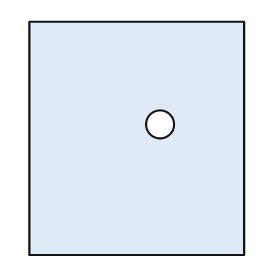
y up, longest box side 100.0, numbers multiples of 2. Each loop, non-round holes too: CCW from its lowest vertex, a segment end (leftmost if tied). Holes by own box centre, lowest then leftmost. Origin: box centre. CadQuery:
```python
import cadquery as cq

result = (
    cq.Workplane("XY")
    .moveTo(-46.0, -50.0)
    .lineTo(46.0, -50.0)
    .lineTo(46.0, 50.0)
    .lineTo(-46.0, 50.0)
    .close()
    .moveTo(10.0, 6.0)
    .circle(6.0)
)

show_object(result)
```